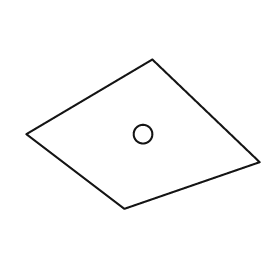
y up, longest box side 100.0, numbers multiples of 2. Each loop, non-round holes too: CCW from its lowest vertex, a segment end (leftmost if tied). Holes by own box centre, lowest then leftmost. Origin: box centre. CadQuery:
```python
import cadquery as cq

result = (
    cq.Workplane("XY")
    .moveTo(-8.0, -32.0)
    .lineTo(50.0, -12.0)
    .lineTo(4.0, 32.0)
    .lineTo(-50.0, 0.0)
    .close()
    .moveTo(0.0, 0.0)
    .circle(4.0)
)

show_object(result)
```